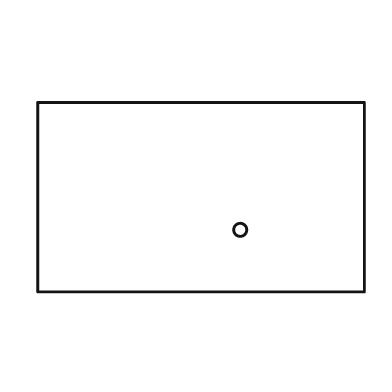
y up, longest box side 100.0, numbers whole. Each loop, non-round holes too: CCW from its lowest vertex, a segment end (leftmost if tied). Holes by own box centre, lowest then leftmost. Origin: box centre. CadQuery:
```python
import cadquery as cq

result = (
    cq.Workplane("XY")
    .moveTo(-50.0, -29.0)
    .lineTo(50.0, -29.0)
    .lineTo(50.0, 29.0)
    .lineTo(-50.0, 29.0)
    .close()
    .moveTo(12.0, -10.0)
    .circle(2.0)
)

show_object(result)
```